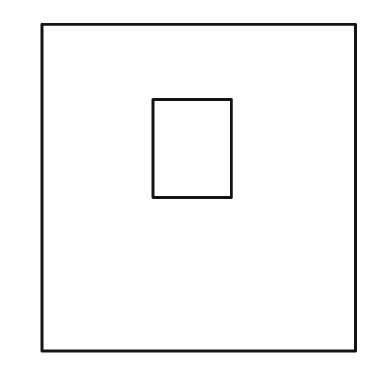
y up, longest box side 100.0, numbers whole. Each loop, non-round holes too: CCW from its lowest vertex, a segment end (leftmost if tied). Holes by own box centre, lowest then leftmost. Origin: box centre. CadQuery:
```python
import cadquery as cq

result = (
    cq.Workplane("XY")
    .moveTo(-48.0, -50.0)
    .lineTo(48.0, -50.0)
    .lineTo(48.0, 50.0)
    .lineTo(-48.0, 50.0)
    .close()
    .moveTo(-14.0, -3.0)
    .lineTo(10.0, -3.0)
    .lineTo(10.0, 27.0)
    .lineTo(-14.0, 27.0)
    .close()
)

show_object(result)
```